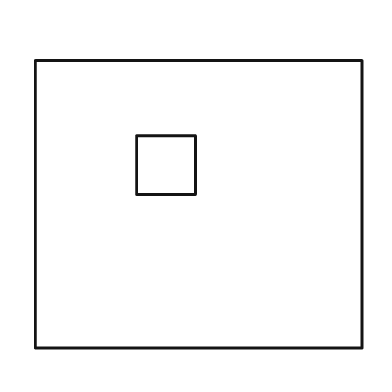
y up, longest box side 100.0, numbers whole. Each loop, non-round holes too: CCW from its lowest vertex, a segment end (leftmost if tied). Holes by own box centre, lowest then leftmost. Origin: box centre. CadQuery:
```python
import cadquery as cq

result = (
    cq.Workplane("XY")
    .moveTo(-50.0, -44.0)
    .lineTo(50.0, -44.0)
    .lineTo(50.0, 44.0)
    .lineTo(-50.0, 44.0)
    .close()
    .moveTo(-19.0, 3.0)
    .lineTo(-1.0, 3.0)
    .lineTo(-1.0, 21.0)
    .lineTo(-19.0, 21.0)
    .close()
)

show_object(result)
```